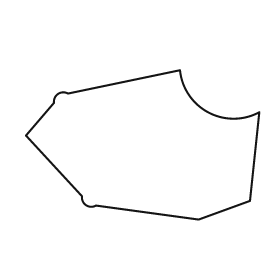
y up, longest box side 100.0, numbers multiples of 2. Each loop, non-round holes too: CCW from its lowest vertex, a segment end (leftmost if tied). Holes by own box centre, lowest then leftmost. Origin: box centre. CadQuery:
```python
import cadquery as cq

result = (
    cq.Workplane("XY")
    .moveTo(24.0, -32.0)
    .lineTo(46.0, -24.0)
    .lineTo(50.0, 14.0)
    .threePointArc((28.0, 14.0), (16.0, 32.0))
    .lineTo(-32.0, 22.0)
    .threePointArc((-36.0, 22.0), (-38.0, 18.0))
    .lineTo(-50.0, 4.0)
    .lineTo(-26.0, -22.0)
    .threePointArc((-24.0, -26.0), (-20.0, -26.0))
    .close()
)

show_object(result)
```